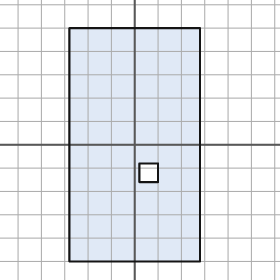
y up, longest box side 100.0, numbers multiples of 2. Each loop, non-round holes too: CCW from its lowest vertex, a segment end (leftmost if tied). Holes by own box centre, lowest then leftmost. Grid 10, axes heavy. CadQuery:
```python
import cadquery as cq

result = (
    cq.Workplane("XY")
    .moveTo(-28.0, -50.0)
    .lineTo(28.0, -50.0)
    .lineTo(28.0, 50.0)
    .lineTo(-28.0, 50.0)
    .close()
    .moveTo(2.0, -16.0)
    .lineTo(10.0, -16.0)
    .lineTo(10.0, -8.0)
    .lineTo(2.0, -8.0)
    .close()
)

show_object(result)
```